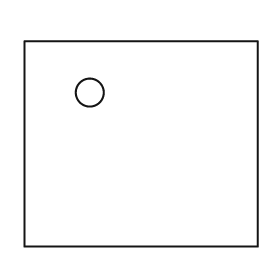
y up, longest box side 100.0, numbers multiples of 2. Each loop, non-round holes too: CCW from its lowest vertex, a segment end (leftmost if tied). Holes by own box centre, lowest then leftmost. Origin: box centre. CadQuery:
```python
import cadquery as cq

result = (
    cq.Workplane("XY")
    .moveTo(-50.0, -44.0)
    .lineTo(50.0, -44.0)
    .lineTo(50.0, 44.0)
    .lineTo(-50.0, 44.0)
    .close()
    .moveTo(-22.0, 22.0)
    .circle(6.0)
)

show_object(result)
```